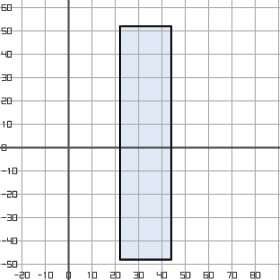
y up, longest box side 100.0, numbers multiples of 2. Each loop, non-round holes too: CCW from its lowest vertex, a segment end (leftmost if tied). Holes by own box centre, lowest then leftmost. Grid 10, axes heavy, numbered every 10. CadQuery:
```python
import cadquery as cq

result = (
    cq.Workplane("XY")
    .moveTo(22.0, -48.0)
    .lineTo(44.0, -48.0)
    .lineTo(44.0, 52.0)
    .lineTo(22.0, 52.0)
    .close()
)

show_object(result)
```